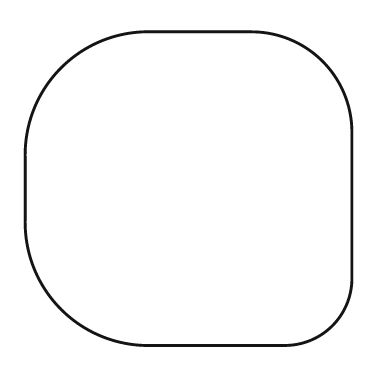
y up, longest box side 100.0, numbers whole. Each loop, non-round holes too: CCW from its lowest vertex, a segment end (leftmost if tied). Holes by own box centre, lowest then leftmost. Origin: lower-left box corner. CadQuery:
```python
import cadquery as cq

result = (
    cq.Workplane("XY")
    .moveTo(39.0, 0.0)
    .lineTo(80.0, 0.0)
    .threePointArc((94.0, 6.0), (100.0, 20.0))
    .lineTo(100.0, 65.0)
    .threePointArc((91.0, 87.0), (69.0, 96.0))
    .lineTo(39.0, 96.0)
    .threePointArc((11.0, 85.0), (0.0, 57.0))
    .lineTo(0.0, 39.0)
    .threePointArc((11.0, 11.0), (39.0, 0.0))
    .close()
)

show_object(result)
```